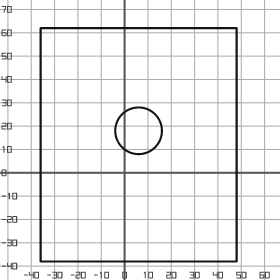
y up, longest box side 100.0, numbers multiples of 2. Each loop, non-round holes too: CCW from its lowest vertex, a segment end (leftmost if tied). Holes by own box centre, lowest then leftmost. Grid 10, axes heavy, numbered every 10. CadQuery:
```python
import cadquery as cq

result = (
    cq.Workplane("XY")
    .moveTo(-36.0, -38.0)
    .lineTo(48.0, -38.0)
    .lineTo(48.0, 62.0)
    .lineTo(-36.0, 62.0)
    .close()
    .moveTo(6.0, 18.0)
    .circle(10.0)
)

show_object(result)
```